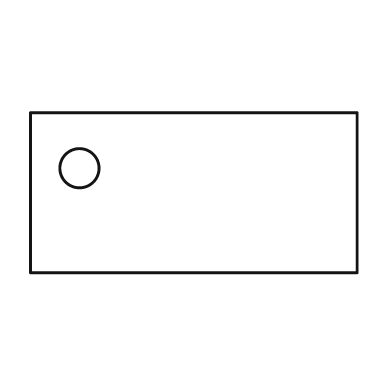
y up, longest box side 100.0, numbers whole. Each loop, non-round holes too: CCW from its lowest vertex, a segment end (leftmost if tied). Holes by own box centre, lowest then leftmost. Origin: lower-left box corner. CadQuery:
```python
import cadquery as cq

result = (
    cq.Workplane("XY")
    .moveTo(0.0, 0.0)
    .lineTo(100.0, 0.0)
    .lineTo(100.0, 49.0)
    .lineTo(0.0, 49.0)
    .close()
    .moveTo(15.0, 32.0)
    .circle(6.0)
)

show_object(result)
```